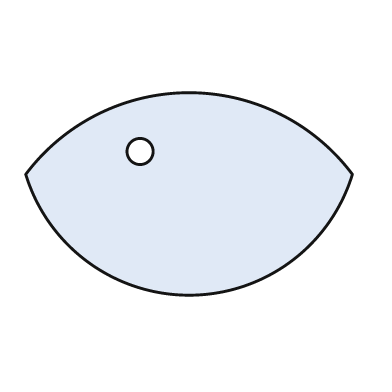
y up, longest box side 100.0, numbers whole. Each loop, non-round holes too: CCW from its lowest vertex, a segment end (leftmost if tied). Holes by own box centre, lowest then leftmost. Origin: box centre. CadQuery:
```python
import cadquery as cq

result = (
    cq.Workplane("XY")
    .moveTo(-50.0, 6.0)
    .threePointArc((0.0, -31.0), (50.0, 6.0))
    .threePointArc((0.0, 31.0), (-50.0, 6.0))
    .close()
    .moveTo(-15.0, 13.0)
    .circle(4.0)
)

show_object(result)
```